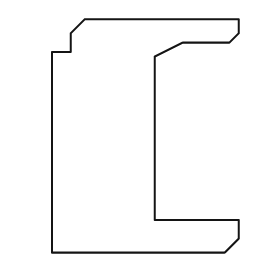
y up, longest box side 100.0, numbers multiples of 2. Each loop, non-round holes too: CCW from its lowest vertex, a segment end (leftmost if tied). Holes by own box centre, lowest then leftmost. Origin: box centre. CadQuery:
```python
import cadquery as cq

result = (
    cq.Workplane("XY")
    .moveTo(-40.0, -50.0)
    .lineTo(34.0, -50.0)
    .lineTo(40.0, -44.0)
    .lineTo(40.0, -36.0)
    .lineTo(4.0, -36.0)
    .lineTo(4.0, 34.0)
    .lineTo(16.0, 40.0)
    .lineTo(36.0, 40.0)
    .lineTo(40.0, 44.0)
    .lineTo(40.0, 50.0)
    .lineTo(-26.0, 50.0)
    .lineTo(-32.0, 44.0)
    .lineTo(-32.0, 36.0)
    .lineTo(-40.0, 36.0)
    .close()
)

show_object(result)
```